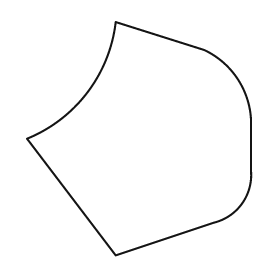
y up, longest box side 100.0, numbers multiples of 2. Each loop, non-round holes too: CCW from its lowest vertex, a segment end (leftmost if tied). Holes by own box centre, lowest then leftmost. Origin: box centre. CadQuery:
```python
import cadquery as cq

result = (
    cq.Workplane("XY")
    .moveTo(-10.0, -50.0)
    .lineTo(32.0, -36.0)
    .threePointArc((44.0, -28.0), (48.0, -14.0))
    .lineTo(48.0, 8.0)
    .threePointArc((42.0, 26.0), (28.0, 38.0))
    .lineTo(-10.0, 50.0)
    .threePointArc((-22.0, 20.0), (-48.0, 0.0))
    .close()
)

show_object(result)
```